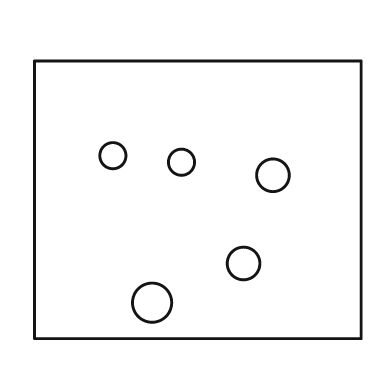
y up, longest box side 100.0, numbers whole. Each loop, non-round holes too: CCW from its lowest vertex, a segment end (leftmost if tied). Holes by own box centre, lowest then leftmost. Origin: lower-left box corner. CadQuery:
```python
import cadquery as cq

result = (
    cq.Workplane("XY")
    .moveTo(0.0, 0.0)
    .lineTo(100.0, 0.0)
    .lineTo(100.0, 85.0)
    .lineTo(0.0, 85.0)
    .close()
    .moveTo(36.0, 11.0)
    .circle(6.0)
    .moveTo(64.0, 23.0)
    .circle(5.0)
    .moveTo(73.0, 50.0)
    .circle(5.0)
    .moveTo(45.0, 54.0)
    .circle(4.0)
    .moveTo(24.0, 56.0)
    .circle(4.0)
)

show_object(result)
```